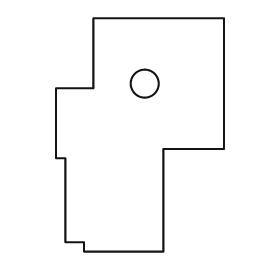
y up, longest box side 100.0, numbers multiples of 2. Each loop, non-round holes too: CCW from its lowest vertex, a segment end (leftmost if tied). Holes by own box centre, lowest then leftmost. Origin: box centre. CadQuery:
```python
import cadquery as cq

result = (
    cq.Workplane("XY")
    .moveTo(-24.0, -50.0)
    .lineTo(10.0, -50.0)
    .lineTo(10.0, -6.0)
    .lineTo(36.0, -6.0)
    .lineTo(36.0, 50.0)
    .lineTo(-20.0, 50.0)
    .lineTo(-20.0, 20.0)
    .lineTo(-36.0, 20.0)
    .lineTo(-36.0, -10.0)
    .lineTo(-32.0, -10.0)
    .lineTo(-32.0, -46.0)
    .lineTo(-24.0, -46.0)
    .close()
    .moveTo(2.0, 22.0)
    .circle(6.0)
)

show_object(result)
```